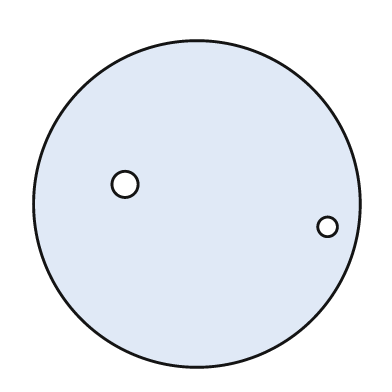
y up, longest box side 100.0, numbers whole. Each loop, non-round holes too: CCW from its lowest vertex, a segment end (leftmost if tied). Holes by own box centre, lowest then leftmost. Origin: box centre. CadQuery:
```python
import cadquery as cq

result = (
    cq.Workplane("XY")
    .moveTo(0.0, 0.0)
    .circle(50.0)
    .moveTo(40.0, -7.0)
    .circle(3.0)
    .moveTo(-22.0, 6.0)
    .circle(4.0)
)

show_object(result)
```